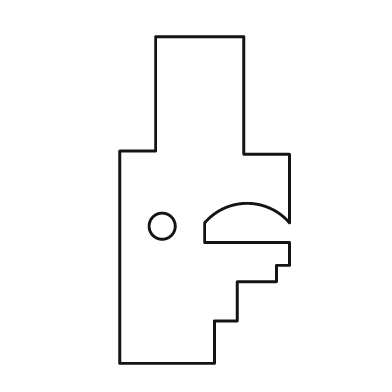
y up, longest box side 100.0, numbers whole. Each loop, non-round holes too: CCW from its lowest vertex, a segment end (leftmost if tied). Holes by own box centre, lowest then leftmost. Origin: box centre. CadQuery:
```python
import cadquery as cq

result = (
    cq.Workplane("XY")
    .moveTo(-26.0, -50.0)
    .lineTo(3.0, -50.0)
    .lineTo(3.0, -37.0)
    .lineTo(10.0, -37.0)
    .lineTo(10.0, -25.0)
    .lineTo(22.0, -25.0)
    .lineTo(22.0, -20.0)
    .lineTo(26.0, -20.0)
    .lineTo(26.0, -13.0)
    .lineTo(0.0, -13.0)
    .lineTo(0.0, -7.0)
    .threePointArc((13.0, -1.0), (26.0, -7.0))
    .lineTo(26.0, 14.0)
    .lineTo(12.0, 14.0)
    .lineTo(12.0, 50.0)
    .lineTo(-15.0, 50.0)
    .lineTo(-15.0, 15.0)
    .lineTo(-26.0, 15.0)
    .close()
    .moveTo(-13.0, -8.0)
    .circle(4.0)
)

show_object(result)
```